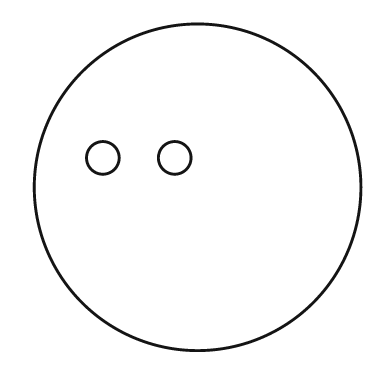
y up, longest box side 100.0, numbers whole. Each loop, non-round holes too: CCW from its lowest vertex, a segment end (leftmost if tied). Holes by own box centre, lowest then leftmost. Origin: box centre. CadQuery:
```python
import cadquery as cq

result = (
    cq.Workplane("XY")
    .moveTo(0.0, 0.0)
    .circle(50.0)
    .moveTo(-29.0, 9.0)
    .circle(5.0)
    .moveTo(-7.0, 9.0)
    .circle(5.0)
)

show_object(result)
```